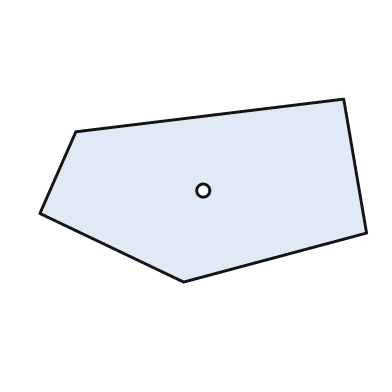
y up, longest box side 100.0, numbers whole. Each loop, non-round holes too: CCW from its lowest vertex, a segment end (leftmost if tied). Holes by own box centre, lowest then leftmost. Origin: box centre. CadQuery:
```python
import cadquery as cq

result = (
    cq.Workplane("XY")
    .moveTo(-6.0, -28.0)
    .lineTo(50.0, -13.0)
    .lineTo(43.0, 28.0)
    .lineTo(-39.0, 18.0)
    .lineTo(-50.0, -7.0)
    .close()
    .moveTo(0.0, 0.0)
    .circle(2.0)
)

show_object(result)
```